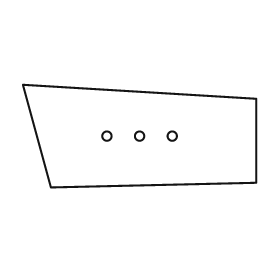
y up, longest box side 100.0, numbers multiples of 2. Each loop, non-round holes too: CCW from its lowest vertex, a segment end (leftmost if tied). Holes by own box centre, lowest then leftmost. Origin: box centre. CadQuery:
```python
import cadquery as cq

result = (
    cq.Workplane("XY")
    .moveTo(-38.0, -22.0)
    .lineTo(50.0, -20.0)
    .lineTo(50.0, 16.0)
    .lineTo(-50.0, 22.0)
    .close()
    .moveTo(-14.0, 0.0)
    .circle(2.0)
    .moveTo(0.0, 0.0)
    .circle(2.0)
    .moveTo(14.0, 0.0)
    .circle(2.0)
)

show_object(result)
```